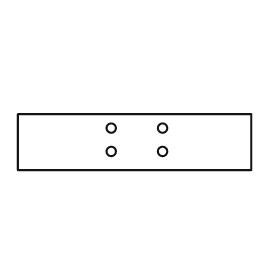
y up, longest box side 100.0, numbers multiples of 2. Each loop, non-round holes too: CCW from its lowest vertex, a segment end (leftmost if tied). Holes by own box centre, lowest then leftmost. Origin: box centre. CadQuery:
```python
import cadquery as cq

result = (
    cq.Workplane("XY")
    .moveTo(-50.0, -12.0)
    .lineTo(50.0, -12.0)
    .lineTo(50.0, 12.0)
    .lineTo(-50.0, 12.0)
    .close()
    .moveTo(-10.0, -4.0)
    .circle(2.0)
    .moveTo(12.0, -4.0)
    .circle(2.0)
    .moveTo(-10.0, 6.0)
    .circle(2.0)
    .moveTo(12.0, 6.0)
    .circle(2.0)
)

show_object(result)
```